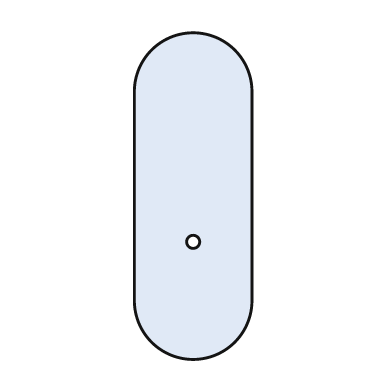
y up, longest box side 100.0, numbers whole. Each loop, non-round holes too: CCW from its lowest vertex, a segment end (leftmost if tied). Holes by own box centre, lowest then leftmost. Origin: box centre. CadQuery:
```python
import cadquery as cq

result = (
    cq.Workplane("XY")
    .moveTo(-18.0, -32.0)
    .threePointArc((0.0, -50.0), (18.0, -32.0))
    .lineTo(18.0, 32.0)
    .threePointArc((0.0, 50.0), (-18.0, 32.0))
    .close()
    .moveTo(0.0, -14.0)
    .circle(2.0)
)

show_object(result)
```